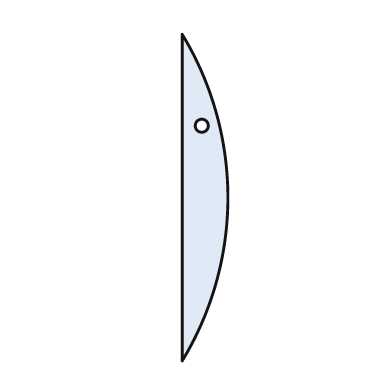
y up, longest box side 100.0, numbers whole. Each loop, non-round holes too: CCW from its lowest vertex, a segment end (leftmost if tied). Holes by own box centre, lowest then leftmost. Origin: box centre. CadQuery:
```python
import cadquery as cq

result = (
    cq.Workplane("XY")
    .moveTo(-7.0, -50.0)
    .threePointArc((7.0, 0.0), (-7.0, 50.0))
    .close()
    .moveTo(-1.0, 22.0)
    .circle(2.0)
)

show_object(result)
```